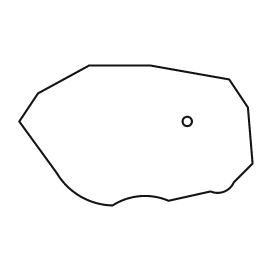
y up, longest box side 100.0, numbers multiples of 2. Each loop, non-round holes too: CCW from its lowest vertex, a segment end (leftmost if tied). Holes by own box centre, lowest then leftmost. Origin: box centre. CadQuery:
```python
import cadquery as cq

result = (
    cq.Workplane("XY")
    .moveTo(-10.0, -30.0)
    .threePointArc((2.0, -26.0), (14.0, -28.0))
    .lineTo(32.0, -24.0)
    .threePointArc((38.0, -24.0), (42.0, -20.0))
    .lineTo(50.0, -12.0)
    .lineTo(48.0, 12.0)
    .lineTo(40.0, 24.0)
    .lineTo(6.0, 30.0)
    .lineTo(-20.0, 30.0)
    .lineTo(-42.0, 18.0)
    .lineTo(-50.0, 6.0)
    .lineTo(-34.0, -16.0)
    .threePointArc((-24.0, -26.0), (-10.0, -30.0))
    .close()
    .moveTo(22.0, 6.0)
    .circle(2.0)
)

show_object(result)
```